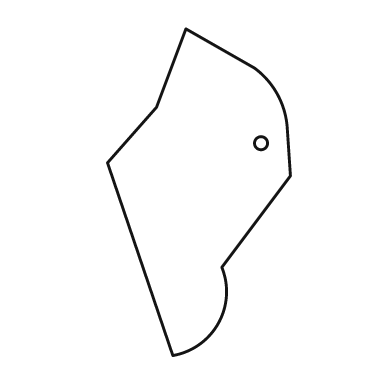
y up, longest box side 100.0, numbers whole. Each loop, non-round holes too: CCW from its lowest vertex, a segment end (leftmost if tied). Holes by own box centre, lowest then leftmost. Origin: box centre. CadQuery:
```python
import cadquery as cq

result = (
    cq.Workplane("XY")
    .moveTo(-8.0, -50.0)
    .threePointArc((6.0, -40.0), (7.0, -23.0))
    .lineTo(28.0, 5.0)
    .lineTo(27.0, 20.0)
    .threePointArc((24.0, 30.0), (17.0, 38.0))
    .lineTo(-4.0, 50.0)
    .lineTo(-13.0, 26.0)
    .lineTo(-28.0, 9.0)
    .close()
    .moveTo(19.0, 15.0)
    .circle(2.0)
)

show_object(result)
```